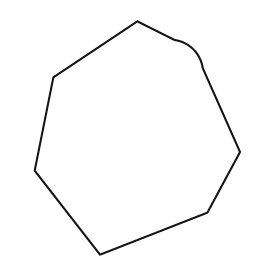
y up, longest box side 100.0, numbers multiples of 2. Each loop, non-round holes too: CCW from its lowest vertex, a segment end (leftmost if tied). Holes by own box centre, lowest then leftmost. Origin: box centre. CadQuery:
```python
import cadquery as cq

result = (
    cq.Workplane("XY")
    .moveTo(-16.0, -50.0)
    .lineTo(30.0, -32.0)
    .lineTo(44.0, -6.0)
    .lineTo(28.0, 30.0)
    .threePointArc((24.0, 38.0), (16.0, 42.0))
    .lineTo(0.0, 50.0)
    .lineTo(-36.0, 26.0)
    .lineTo(-44.0, -14.0)
    .close()
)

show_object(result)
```